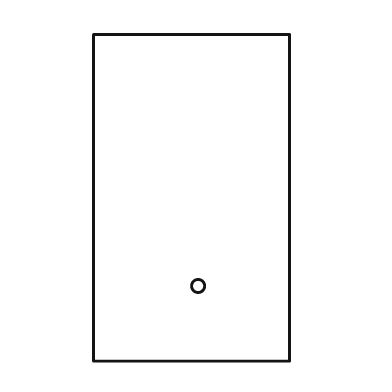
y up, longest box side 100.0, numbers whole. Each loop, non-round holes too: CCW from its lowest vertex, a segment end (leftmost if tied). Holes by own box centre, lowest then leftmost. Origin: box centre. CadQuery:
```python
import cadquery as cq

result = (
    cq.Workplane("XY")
    .moveTo(-30.0, -50.0)
    .lineTo(30.0, -50.0)
    .lineTo(30.0, 50.0)
    .lineTo(-30.0, 50.0)
    .close()
    .moveTo(2.0, -27.0)
    .circle(2.0)
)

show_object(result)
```